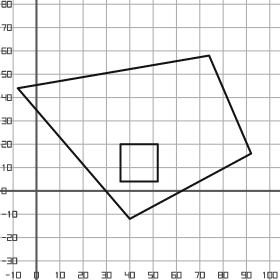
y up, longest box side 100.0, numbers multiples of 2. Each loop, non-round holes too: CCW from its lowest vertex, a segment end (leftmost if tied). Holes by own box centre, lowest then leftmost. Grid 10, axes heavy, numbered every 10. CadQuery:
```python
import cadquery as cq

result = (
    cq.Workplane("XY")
    .moveTo(40.0, -12.0)
    .lineTo(92.0, 16.0)
    .lineTo(74.0, 58.0)
    .lineTo(-8.0, 44.0)
    .close()
    .moveTo(36.0, 4.0)
    .lineTo(52.0, 4.0)
    .lineTo(52.0, 20.0)
    .lineTo(36.0, 20.0)
    .close()
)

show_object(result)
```